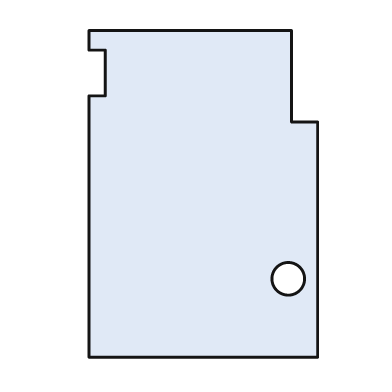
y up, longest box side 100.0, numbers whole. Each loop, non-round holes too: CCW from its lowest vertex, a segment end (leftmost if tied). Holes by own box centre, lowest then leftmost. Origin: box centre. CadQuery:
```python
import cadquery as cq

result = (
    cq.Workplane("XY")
    .moveTo(-35.0, -50.0)
    .lineTo(35.0, -50.0)
    .lineTo(35.0, 22.0)
    .lineTo(27.0, 22.0)
    .lineTo(27.0, 50.0)
    .lineTo(-35.0, 50.0)
    .lineTo(-35.0, 44.0)
    .lineTo(-30.0, 44.0)
    .lineTo(-30.0, 30.0)
    .lineTo(-35.0, 30.0)
    .close()
    .moveTo(26.0, -26.0)
    .circle(5.0)
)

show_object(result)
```